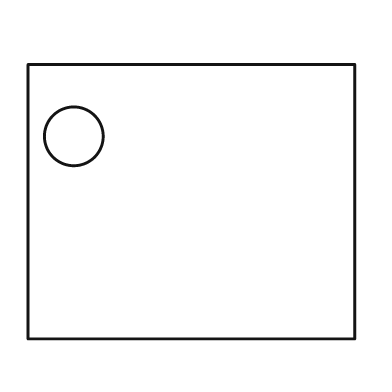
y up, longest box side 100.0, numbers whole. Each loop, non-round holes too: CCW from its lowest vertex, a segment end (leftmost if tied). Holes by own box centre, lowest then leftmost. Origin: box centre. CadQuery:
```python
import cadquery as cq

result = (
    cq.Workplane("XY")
    .moveTo(-50.0, -42.0)
    .lineTo(50.0, -42.0)
    .lineTo(50.0, 42.0)
    .lineTo(-50.0, 42.0)
    .close()
    .moveTo(-36.0, 20.0)
    .circle(9.0)
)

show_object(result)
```